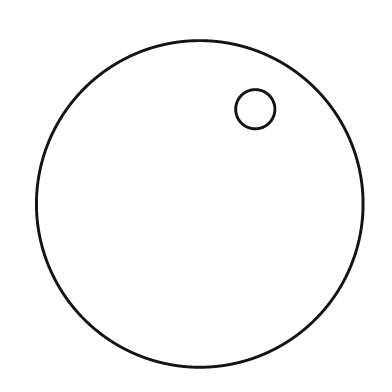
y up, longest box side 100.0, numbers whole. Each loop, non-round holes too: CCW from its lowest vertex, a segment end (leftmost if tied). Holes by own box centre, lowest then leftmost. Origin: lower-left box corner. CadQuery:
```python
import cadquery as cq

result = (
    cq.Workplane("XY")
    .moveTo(50.0, 50.0)
    .circle(50.0)
    .moveTo(67.0, 79.0)
    .circle(6.0)
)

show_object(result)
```